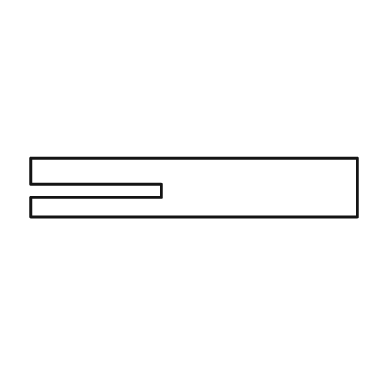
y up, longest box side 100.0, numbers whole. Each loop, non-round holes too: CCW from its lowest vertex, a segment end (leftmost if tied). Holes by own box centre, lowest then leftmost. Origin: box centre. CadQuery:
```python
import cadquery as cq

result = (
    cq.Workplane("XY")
    .moveTo(-50.0, -9.0)
    .lineTo(50.0, -9.0)
    .lineTo(50.0, 9.0)
    .lineTo(-50.0, 9.0)
    .lineTo(-50.0, 1.0)
    .lineTo(-10.0, 1.0)
    .lineTo(-10.0, -3.0)
    .lineTo(-50.0, -3.0)
    .close()
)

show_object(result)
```